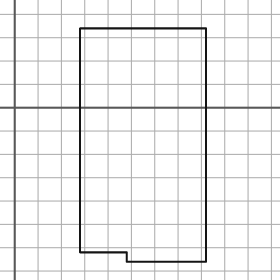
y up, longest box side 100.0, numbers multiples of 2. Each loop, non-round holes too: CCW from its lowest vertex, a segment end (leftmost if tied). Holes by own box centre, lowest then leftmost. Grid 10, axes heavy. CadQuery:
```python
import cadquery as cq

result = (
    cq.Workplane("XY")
    .moveTo(48.0, -66.0)
    .lineTo(82.0, -66.0)
    .lineTo(82.0, 34.0)
    .lineTo(28.0, 34.0)
    .lineTo(28.0, -62.0)
    .lineTo(48.0, -62.0)
    .close()
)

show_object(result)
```